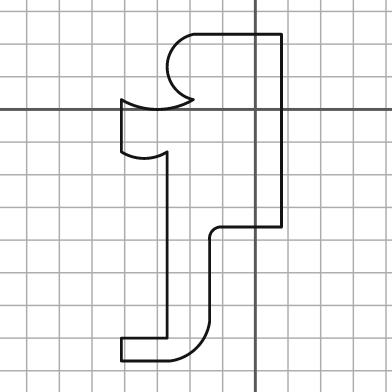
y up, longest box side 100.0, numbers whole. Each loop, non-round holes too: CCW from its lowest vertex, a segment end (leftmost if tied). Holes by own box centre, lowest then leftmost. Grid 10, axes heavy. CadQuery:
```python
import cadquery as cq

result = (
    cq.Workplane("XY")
    .moveTo(-41.0, -77.0)
    .lineTo(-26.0, -77.0)
    .threePointArc((-18.0, -73.0), (-14.0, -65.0))
    .lineTo(-14.0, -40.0)
    .threePointArc((-13.0, -37.0), (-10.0, -36.0))
    .lineTo(8.0, -36.0)
    .lineTo(8.0, 23.0)
    .lineTo(-19.0, 23.0)
    .threePointArc((-27.0, 13.0), (-19.0, 3.0))
    .threePointArc((-30.0, 0.0), (-41.0, 3.0))
    .lineTo(-41.0, -13.0)
    .threePointArc((-34.0, -15.0), (-27.0, -13.0))
    .lineTo(-27.0, -70.0)
    .lineTo(-41.0, -70.0)
    .close()
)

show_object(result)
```